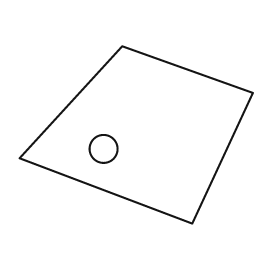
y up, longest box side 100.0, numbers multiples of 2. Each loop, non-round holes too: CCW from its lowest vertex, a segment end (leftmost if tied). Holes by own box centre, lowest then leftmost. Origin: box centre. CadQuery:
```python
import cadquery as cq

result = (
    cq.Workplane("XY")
    .moveTo(24.0, -38.0)
    .lineTo(50.0, 18.0)
    .lineTo(-6.0, 38.0)
    .lineTo(-50.0, -10.0)
    .close()
    .moveTo(-14.0, -6.0)
    .circle(6.0)
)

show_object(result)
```